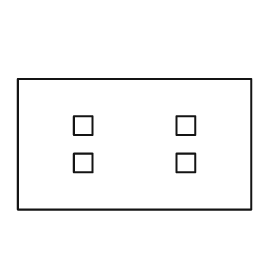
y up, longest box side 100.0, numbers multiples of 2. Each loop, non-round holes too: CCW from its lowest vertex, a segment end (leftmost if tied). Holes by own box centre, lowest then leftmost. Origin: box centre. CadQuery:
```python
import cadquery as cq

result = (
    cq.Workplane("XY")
    .moveTo(-50.0, -28.0)
    .lineTo(50.0, -28.0)
    .lineTo(50.0, 28.0)
    .lineTo(-50.0, 28.0)
    .close()
    .moveTo(-26.0, -12.0)
    .lineTo(-18.0, -12.0)
    .lineTo(-18.0, -4.0)
    .lineTo(-26.0, -4.0)
    .close()
    .moveTo(18.0, -12.0)
    .lineTo(26.0, -12.0)
    .lineTo(26.0, -4.0)
    .lineTo(18.0, -4.0)
    .close()
    .moveTo(-26.0, 4.0)
    .lineTo(-18.0, 4.0)
    .lineTo(-18.0, 12.0)
    .lineTo(-26.0, 12.0)
    .close()
    .moveTo(18.0, 4.0)
    .lineTo(26.0, 4.0)
    .lineTo(26.0, 12.0)
    .lineTo(18.0, 12.0)
    .close()
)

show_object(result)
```